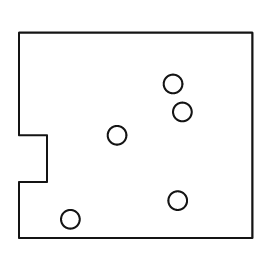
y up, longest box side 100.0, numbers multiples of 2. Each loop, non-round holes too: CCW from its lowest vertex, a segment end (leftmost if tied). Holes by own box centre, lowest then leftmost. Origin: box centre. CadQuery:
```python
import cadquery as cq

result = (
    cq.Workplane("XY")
    .moveTo(-50.0, -44.0)
    .lineTo(50.0, -44.0)
    .lineTo(50.0, 44.0)
    .lineTo(-50.0, 44.0)
    .lineTo(-50.0, 0.0)
    .lineTo(-38.0, 0.0)
    .lineTo(-38.0, -20.0)
    .lineTo(-50.0, -20.0)
    .close()
    .moveTo(-28.0, -36.0)
    .circle(4.0)
    .moveTo(18.0, -28.0)
    .circle(4.0)
    .moveTo(-8.0, 0.0)
    .circle(4.0)
    .moveTo(20.0, 10.0)
    .circle(4.0)
    .moveTo(16.0, 22.0)
    .circle(4.0)
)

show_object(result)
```